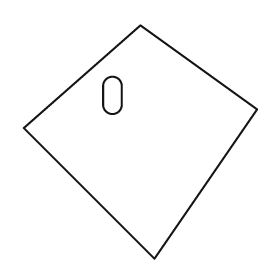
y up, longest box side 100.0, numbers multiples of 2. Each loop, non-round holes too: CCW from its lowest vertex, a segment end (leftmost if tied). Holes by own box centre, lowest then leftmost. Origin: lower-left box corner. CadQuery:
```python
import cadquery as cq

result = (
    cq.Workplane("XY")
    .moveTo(56.0, 0.0)
    .lineTo(100.0, 64.0)
    .lineTo(50.0, 100.0)
    .lineTo(0.0, 56.0)
    .close()
    .moveTo(34.0, 66.0)
    .threePointArc((38.0, 62.0), (42.0, 66.0))
    .lineTo(42.0, 74.0)
    .threePointArc((38.0, 78.0), (34.0, 74.0))
    .close()
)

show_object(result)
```